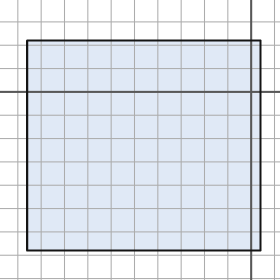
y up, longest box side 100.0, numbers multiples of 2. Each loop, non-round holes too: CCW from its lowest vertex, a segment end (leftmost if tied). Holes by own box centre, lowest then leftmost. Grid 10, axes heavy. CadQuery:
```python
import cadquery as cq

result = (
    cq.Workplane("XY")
    .moveTo(-96.0, -68.0)
    .lineTo(4.0, -68.0)
    .lineTo(4.0, 22.0)
    .lineTo(-96.0, 22.0)
    .close()
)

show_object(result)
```